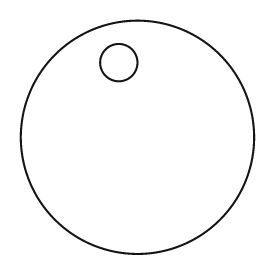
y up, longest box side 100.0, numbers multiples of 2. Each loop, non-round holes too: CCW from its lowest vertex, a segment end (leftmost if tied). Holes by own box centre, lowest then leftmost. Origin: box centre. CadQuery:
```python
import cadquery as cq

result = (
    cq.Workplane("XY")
    .moveTo(0.0, 0.0)
    .circle(50.0)
    .moveTo(-8.0, 32.0)
    .circle(8.0)
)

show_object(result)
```